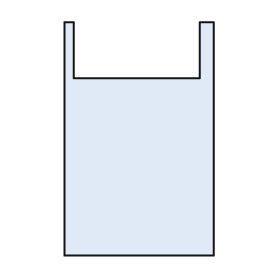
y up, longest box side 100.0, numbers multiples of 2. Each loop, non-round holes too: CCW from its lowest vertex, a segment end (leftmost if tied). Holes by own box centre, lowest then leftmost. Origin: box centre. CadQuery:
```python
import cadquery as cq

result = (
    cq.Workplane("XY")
    .moveTo(-32.0, -50.0)
    .lineTo(32.0, -50.0)
    .lineTo(32.0, 50.0)
    .lineTo(26.0, 50.0)
    .lineTo(26.0, 26.0)
    .lineTo(-28.0, 26.0)
    .lineTo(-28.0, 50.0)
    .lineTo(-32.0, 50.0)
    .close()
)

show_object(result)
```